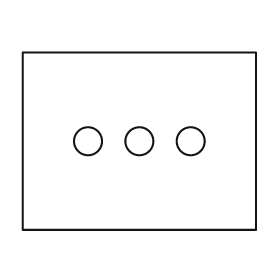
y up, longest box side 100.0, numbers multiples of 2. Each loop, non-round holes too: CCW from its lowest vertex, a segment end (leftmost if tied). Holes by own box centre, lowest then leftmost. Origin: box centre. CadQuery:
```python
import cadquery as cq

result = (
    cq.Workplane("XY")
    .moveTo(-50.0, -38.0)
    .lineTo(50.0, -38.0)
    .lineTo(50.0, 38.0)
    .lineTo(-50.0, 38.0)
    .close()
    .moveTo(-22.0, 0.0)
    .circle(6.0)
    .moveTo(0.0, 0.0)
    .circle(6.0)
    .moveTo(22.0, 0.0)
    .circle(6.0)
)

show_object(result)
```